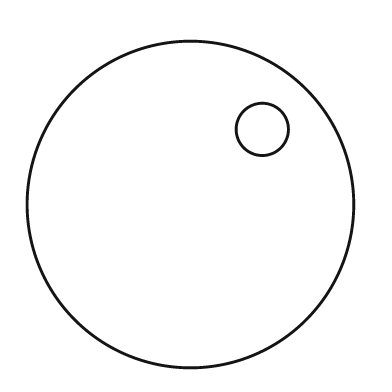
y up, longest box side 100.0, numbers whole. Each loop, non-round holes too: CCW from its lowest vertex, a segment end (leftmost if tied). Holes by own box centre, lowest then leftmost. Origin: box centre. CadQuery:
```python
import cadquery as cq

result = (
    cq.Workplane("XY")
    .moveTo(0.0, 0.0)
    .circle(50.0)
    .moveTo(22.0, 23.0)
    .circle(8.0)
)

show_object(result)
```